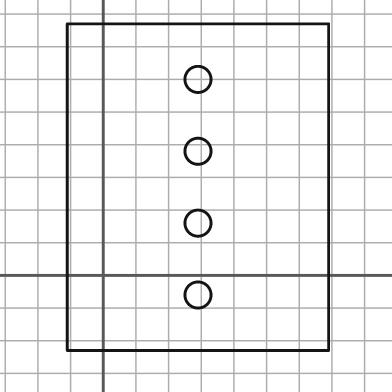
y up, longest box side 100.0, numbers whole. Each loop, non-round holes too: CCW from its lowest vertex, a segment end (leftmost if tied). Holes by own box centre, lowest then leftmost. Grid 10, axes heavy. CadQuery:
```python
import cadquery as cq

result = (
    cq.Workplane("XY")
    .moveTo(-11.0, -23.0)
    .lineTo(69.0, -23.0)
    .lineTo(69.0, 77.0)
    .lineTo(-11.0, 77.0)
    .close()
    .moveTo(29.0, -6.0)
    .circle(4.0)
    .moveTo(29.0, 16.0)
    .circle(4.0)
    .moveTo(29.0, 38.0)
    .circle(4.0)
    .moveTo(29.0, 60.0)
    .circle(4.0)
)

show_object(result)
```